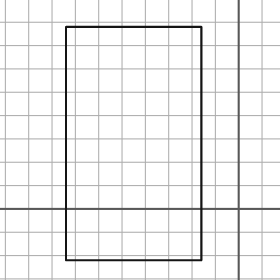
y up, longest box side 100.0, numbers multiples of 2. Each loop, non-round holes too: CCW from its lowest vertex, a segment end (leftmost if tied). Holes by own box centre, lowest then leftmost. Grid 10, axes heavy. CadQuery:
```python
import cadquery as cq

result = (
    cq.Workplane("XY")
    .moveTo(-74.0, -22.0)
    .lineTo(-16.0, -22.0)
    .lineTo(-16.0, 78.0)
    .lineTo(-74.0, 78.0)
    .close()
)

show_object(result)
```